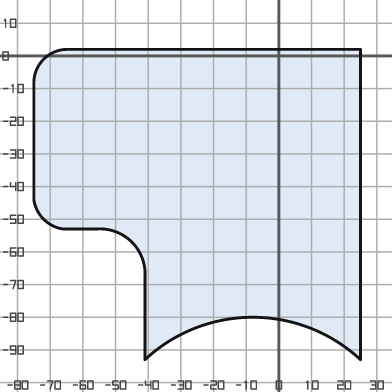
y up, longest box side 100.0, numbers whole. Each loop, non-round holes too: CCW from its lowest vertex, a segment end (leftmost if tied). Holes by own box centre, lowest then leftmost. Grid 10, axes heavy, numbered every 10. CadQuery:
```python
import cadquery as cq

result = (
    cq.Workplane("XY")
    .moveTo(-41.0, -93.0)
    .threePointArc((-8.0, -80.0), (25.0, -93.0))
    .lineTo(25.0, 2.0)
    .lineTo(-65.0, 2.0)
    .threePointArc((-72.0, -1.0), (-75.0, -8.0))
    .lineTo(-75.0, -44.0)
    .threePointArc((-72.0, -50.0), (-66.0, -53.0))
    .lineTo(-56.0, -53.0)
    .threePointArc((-45.0, -57.0), (-41.0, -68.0))
    .close()
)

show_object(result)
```